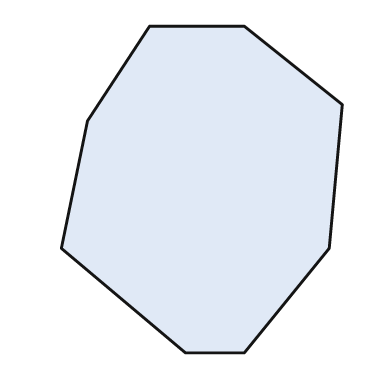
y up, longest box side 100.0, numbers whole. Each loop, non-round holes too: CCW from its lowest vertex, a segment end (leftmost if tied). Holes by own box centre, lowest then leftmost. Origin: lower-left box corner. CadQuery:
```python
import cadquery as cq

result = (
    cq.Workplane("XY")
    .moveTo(38.0, 0.0)
    .lineTo(56.0, 0.0)
    .lineTo(82.0, 32.0)
    .lineTo(86.0, 76.0)
    .lineTo(56.0, 100.0)
    .lineTo(27.0, 100.0)
    .lineTo(8.0, 71.0)
    .lineTo(0.0, 32.0)
    .close()
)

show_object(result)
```